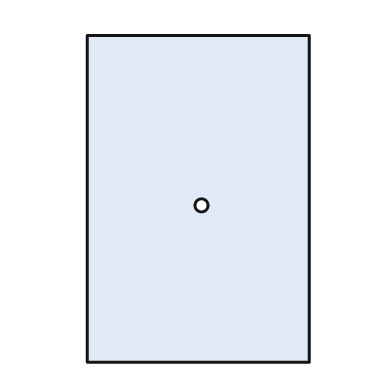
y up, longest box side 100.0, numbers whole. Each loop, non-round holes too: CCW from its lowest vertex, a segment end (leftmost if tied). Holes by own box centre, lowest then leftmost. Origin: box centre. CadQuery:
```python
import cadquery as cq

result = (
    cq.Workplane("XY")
    .moveTo(-34.0, -50.0)
    .lineTo(34.0, -50.0)
    .lineTo(34.0, 50.0)
    .lineTo(-34.0, 50.0)
    .close()
    .moveTo(1.0, -2.0)
    .circle(2.0)
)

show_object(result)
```